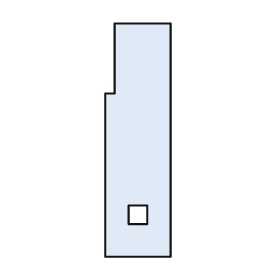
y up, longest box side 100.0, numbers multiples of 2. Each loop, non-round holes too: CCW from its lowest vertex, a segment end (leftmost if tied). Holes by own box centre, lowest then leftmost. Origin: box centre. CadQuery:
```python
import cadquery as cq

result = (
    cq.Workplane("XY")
    .moveTo(-14.0, -50.0)
    .lineTo(14.0, -50.0)
    .lineTo(14.0, 50.0)
    .lineTo(-10.0, 50.0)
    .lineTo(-10.0, 20.0)
    .lineTo(-14.0, 20.0)
    .close()
    .moveTo(-4.0, -36.0)
    .lineTo(4.0, -36.0)
    .lineTo(4.0, -28.0)
    .lineTo(-4.0, -28.0)
    .close()
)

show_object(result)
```